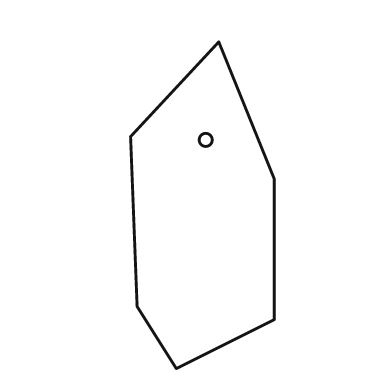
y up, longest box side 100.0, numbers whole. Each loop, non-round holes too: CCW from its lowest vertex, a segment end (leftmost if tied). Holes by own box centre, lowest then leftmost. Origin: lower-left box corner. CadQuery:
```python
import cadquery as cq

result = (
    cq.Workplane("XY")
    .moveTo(14.0, 0.0)
    .lineTo(44.0, 15.0)
    .lineTo(44.0, 58.0)
    .lineTo(27.0, 100.0)
    .lineTo(0.0, 71.0)
    .lineTo(2.0, 19.0)
    .close()
    .moveTo(23.0, 70.0)
    .circle(2.0)
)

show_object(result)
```